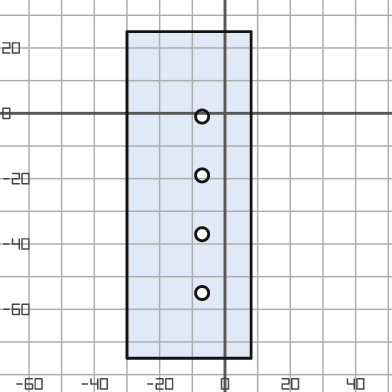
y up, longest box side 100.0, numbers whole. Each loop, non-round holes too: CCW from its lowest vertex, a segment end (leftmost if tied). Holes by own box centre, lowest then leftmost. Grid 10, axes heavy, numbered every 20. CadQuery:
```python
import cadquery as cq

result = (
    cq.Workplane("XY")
    .moveTo(-30.0, -75.0)
    .lineTo(8.0, -75.0)
    .lineTo(8.0, 25.0)
    .lineTo(-30.0, 25.0)
    .close()
    .moveTo(-7.0, -55.0)
    .circle(2.0)
    .moveTo(-7.0, -37.0)
    .circle(2.0)
    .moveTo(-7.0, -19.0)
    .circle(2.0)
    .moveTo(-7.0, -1.0)
    .circle(2.0)
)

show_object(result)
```